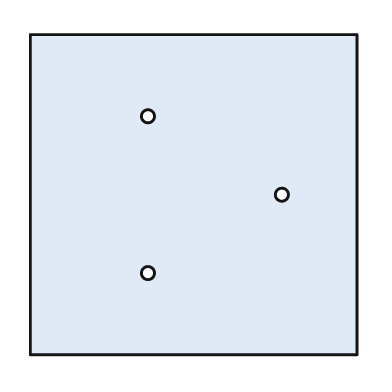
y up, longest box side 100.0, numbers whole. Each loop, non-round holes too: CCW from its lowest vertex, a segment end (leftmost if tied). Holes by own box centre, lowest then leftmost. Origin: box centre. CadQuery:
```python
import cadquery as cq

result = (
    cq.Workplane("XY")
    .moveTo(-50.0, -49.0)
    .lineTo(50.0, -49.0)
    .lineTo(50.0, 49.0)
    .lineTo(-50.0, 49.0)
    .close()
    .moveTo(-14.0, -24.0)
    .circle(2.0)
    .moveTo(27.0, 0.0)
    .circle(2.0)
    .moveTo(-14.0, 24.0)
    .circle(2.0)
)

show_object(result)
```